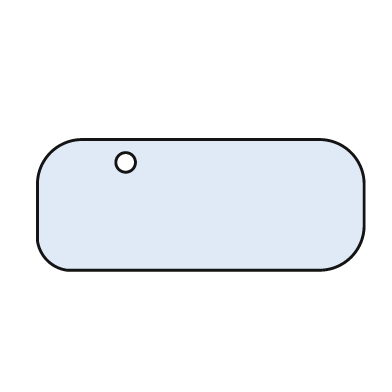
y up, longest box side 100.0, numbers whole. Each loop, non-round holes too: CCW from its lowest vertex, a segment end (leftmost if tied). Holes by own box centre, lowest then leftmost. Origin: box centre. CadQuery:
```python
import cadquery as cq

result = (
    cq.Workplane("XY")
    .moveTo(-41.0, -20.0)
    .lineTo(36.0, -20.0)
    .threePointArc((46.0, -16.0), (50.0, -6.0))
    .lineTo(50.0, 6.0)
    .threePointArc((46.0, 16.0), (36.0, 20.0))
    .lineTo(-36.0, 20.0)
    .threePointArc((-46.0, 16.0), (-50.0, 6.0))
    .lineTo(-50.0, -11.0)
    .threePointArc((-47.0, -17.0), (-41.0, -20.0))
    .close()
    .moveTo(-23.0, 13.0)
    .circle(3.0)
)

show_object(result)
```